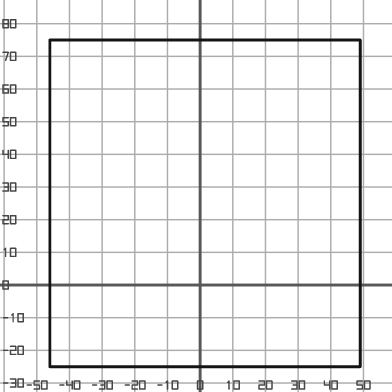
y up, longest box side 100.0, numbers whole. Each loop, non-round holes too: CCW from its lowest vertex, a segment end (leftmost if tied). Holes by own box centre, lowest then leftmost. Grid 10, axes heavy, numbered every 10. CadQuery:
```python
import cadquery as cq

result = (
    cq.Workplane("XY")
    .moveTo(-46.0, -25.0)
    .lineTo(49.0, -25.0)
    .lineTo(49.0, 75.0)
    .lineTo(-46.0, 75.0)
    .close()
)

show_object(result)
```